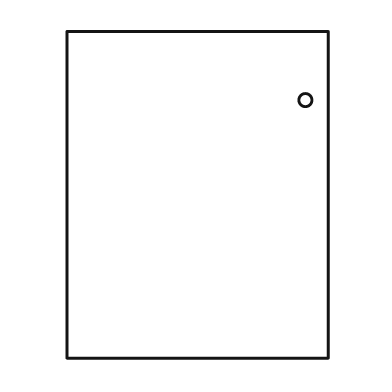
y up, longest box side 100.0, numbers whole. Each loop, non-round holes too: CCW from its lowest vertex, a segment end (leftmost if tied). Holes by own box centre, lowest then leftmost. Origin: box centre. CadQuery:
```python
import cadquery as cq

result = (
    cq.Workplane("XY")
    .moveTo(-40.0, -50.0)
    .lineTo(40.0, -50.0)
    .lineTo(40.0, 50.0)
    .lineTo(-40.0, 50.0)
    .close()
    .moveTo(33.0, 29.0)
    .circle(2.0)
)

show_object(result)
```